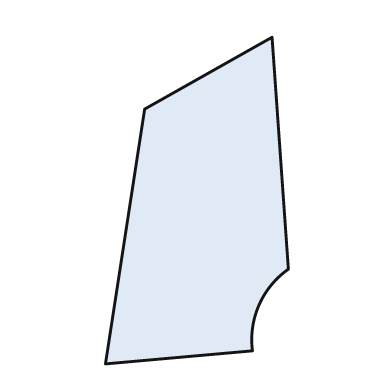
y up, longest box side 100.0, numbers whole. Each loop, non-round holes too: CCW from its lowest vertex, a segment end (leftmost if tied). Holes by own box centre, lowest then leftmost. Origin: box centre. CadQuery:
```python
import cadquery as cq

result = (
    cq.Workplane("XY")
    .moveTo(-28.0, -50.0)
    .lineTo(17.0, -46.0)
    .threePointArc((19.0, -32.0), (28.0, -21.0))
    .lineTo(23.0, 50.0)
    .lineTo(-16.0, 28.0)
    .close()
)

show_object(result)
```